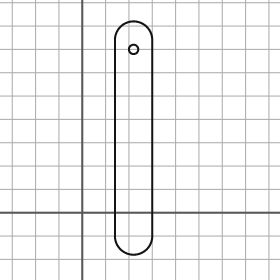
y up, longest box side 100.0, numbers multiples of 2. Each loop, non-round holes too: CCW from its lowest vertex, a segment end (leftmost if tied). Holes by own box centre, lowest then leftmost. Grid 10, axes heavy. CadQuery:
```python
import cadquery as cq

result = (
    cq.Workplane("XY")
    .moveTo(14.0, -10.0)
    .threePointArc((22.0, -18.0), (30.0, -10.0))
    .lineTo(30.0, 74.0)
    .threePointArc((22.0, 82.0), (14.0, 74.0))
    .close()
    .moveTo(22.0, 70.0)
    .circle(2.0)
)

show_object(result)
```